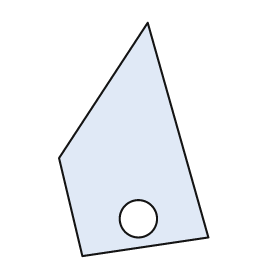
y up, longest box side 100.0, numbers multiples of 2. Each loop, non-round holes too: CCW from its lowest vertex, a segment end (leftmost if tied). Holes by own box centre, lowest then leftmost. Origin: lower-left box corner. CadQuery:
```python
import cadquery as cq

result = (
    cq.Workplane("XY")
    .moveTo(10.0, 0.0)
    .lineTo(64.0, 8.0)
    .lineTo(38.0, 100.0)
    .lineTo(0.0, 42.0)
    .close()
    .moveTo(34.0, 16.0)
    .circle(8.0)
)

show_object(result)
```